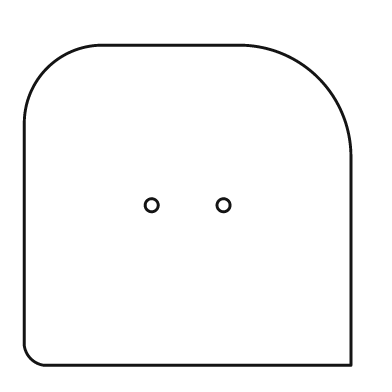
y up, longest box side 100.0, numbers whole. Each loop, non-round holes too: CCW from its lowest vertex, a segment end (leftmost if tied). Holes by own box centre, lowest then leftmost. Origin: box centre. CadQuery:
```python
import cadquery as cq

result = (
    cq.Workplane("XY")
    .moveTo(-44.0, -49.0)
    .lineTo(50.0, -49.0)
    .lineTo(50.0, 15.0)
    .threePointArc((40.0, 39.0), (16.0, 49.0))
    .lineTo(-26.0, 49.0)
    .threePointArc((-43.0, 42.0), (-50.0, 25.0))
    .lineTo(-50.0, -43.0)
    .threePointArc((-48.0, -47.0), (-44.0, -49.0))
    .close()
    .moveTo(-11.0, 0.0)
    .circle(2.0)
    .moveTo(11.0, 0.0)
    .circle(2.0)
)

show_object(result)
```